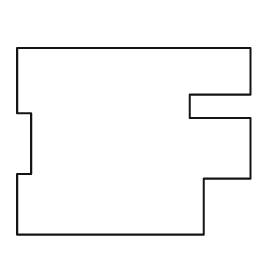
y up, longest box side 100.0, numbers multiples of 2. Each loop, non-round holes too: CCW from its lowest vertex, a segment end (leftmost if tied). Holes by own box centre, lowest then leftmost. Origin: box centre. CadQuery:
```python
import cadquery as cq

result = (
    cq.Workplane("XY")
    .moveTo(-50.0, -40.0)
    .lineTo(30.0, -40.0)
    .lineTo(30.0, -16.0)
    .lineTo(50.0, -16.0)
    .lineTo(50.0, 10.0)
    .lineTo(24.0, 10.0)
    .lineTo(24.0, 20.0)
    .lineTo(50.0, 20.0)
    .lineTo(50.0, 40.0)
    .lineTo(-50.0, 40.0)
    .lineTo(-50.0, 12.0)
    .lineTo(-44.0, 12.0)
    .lineTo(-44.0, -14.0)
    .lineTo(-50.0, -14.0)
    .close()
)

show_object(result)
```